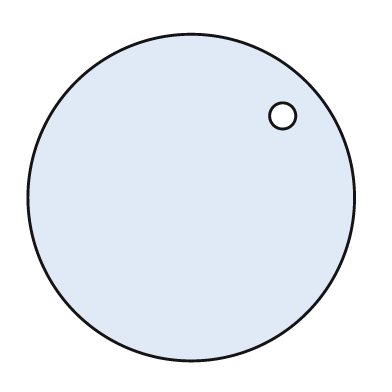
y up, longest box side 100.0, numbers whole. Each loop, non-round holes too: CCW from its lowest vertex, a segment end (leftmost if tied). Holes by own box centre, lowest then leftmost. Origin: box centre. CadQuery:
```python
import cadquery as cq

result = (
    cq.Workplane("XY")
    .moveTo(0.0, 0.0)
    .circle(50.0)
    .moveTo(28.0, 25.0)
    .circle(4.0)
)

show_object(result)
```